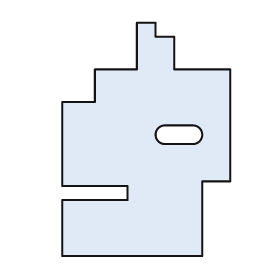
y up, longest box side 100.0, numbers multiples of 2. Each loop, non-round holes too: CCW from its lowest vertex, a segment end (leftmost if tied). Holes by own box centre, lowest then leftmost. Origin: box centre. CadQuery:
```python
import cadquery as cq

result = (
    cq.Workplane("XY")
    .moveTo(-36.0, -50.0)
    .lineTo(24.0, -50.0)
    .lineTo(24.0, -18.0)
    .lineTo(36.0, -18.0)
    .lineTo(36.0, 30.0)
    .lineTo(12.0, 30.0)
    .lineTo(12.0, 44.0)
    .lineTo(4.0, 44.0)
    .lineTo(4.0, 50.0)
    .lineTo(-4.0, 50.0)
    .lineTo(-4.0, 30.0)
    .lineTo(-22.0, 30.0)
    .lineTo(-22.0, 16.0)
    .lineTo(-36.0, 16.0)
    .lineTo(-36.0, -20.0)
    .lineTo(-8.0, -20.0)
    .lineTo(-8.0, -26.0)
    .lineTo(-36.0, -26.0)
    .close()
    .moveTo(8.0, -2.0)
    .lineTo(20.0, -2.0)
    .threePointArc((24.0, 2.0), (20.0, 6.0))
    .lineTo(8.0, 6.0)
    .threePointArc((4.0, 2.0), (8.0, -2.0))
    .close()
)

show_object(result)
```